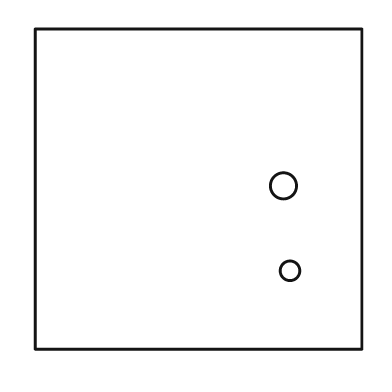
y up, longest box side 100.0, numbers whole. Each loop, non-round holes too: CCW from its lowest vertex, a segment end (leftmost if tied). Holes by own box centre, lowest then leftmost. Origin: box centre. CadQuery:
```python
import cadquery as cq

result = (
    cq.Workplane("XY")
    .moveTo(-50.0, -49.0)
    .lineTo(50.0, -49.0)
    .lineTo(50.0, 49.0)
    .lineTo(-50.0, 49.0)
    .close()
    .moveTo(28.0, -25.0)
    .circle(3.0)
    .moveTo(26.0, 1.0)
    .circle(4.0)
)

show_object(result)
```